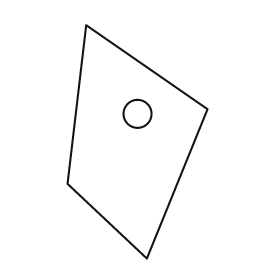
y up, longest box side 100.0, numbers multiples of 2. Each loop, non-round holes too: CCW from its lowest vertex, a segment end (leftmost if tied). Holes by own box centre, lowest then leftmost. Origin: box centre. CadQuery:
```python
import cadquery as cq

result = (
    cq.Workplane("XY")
    .moveTo(4.0, -50.0)
    .lineTo(30.0, 14.0)
    .lineTo(-22.0, 50.0)
    .lineTo(-30.0, -18.0)
    .close()
    .moveTo(0.0, 12.0)
    .circle(6.0)
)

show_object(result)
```